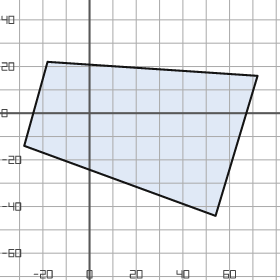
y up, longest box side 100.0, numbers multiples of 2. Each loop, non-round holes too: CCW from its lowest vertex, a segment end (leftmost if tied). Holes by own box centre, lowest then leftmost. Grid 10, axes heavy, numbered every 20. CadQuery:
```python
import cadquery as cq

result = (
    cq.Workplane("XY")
    .moveTo(54.0, -44.0)
    .lineTo(72.0, 16.0)
    .lineTo(-18.0, 22.0)
    .lineTo(-28.0, -14.0)
    .close()
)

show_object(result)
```